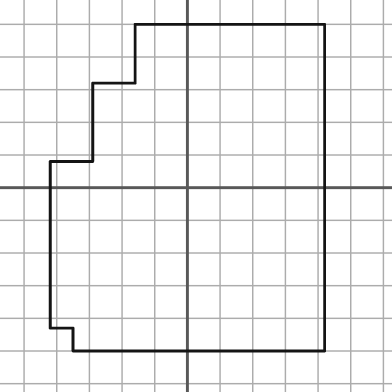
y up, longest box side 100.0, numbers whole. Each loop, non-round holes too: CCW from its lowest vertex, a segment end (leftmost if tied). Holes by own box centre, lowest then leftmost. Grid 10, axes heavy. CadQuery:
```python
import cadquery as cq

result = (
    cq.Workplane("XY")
    .moveTo(-35.0, -50.0)
    .lineTo(42.0, -50.0)
    .lineTo(42.0, 50.0)
    .lineTo(-16.0, 50.0)
    .lineTo(-16.0, 32.0)
    .lineTo(-29.0, 32.0)
    .lineTo(-29.0, 8.0)
    .lineTo(-42.0, 8.0)
    .lineTo(-42.0, -43.0)
    .lineTo(-35.0, -43.0)
    .close()
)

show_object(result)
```